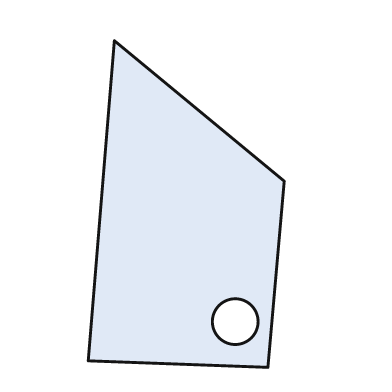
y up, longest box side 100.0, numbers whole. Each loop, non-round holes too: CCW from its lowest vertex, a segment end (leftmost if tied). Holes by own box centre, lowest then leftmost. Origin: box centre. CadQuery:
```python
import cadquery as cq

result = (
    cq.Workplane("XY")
    .moveTo(25.0, -50.0)
    .lineTo(30.0, 7.0)
    .lineTo(-22.0, 50.0)
    .lineTo(-30.0, -48.0)
    .close()
    .moveTo(15.0, -36.0)
    .circle(7.0)
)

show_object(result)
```